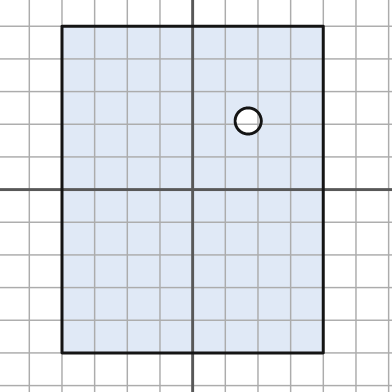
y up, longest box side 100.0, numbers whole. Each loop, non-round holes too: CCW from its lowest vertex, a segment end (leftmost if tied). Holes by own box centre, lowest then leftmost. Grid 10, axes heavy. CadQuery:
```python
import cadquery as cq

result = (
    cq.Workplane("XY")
    .moveTo(-40.0, -50.0)
    .lineTo(40.0, -50.0)
    .lineTo(40.0, 50.0)
    .lineTo(-40.0, 50.0)
    .close()
    .moveTo(17.0, 21.0)
    .circle(4.0)
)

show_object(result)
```